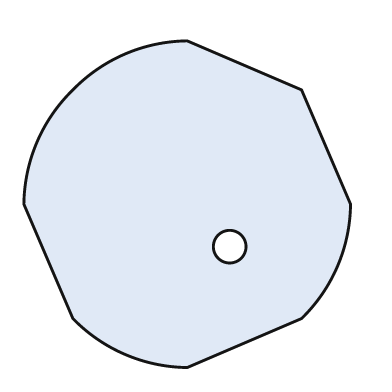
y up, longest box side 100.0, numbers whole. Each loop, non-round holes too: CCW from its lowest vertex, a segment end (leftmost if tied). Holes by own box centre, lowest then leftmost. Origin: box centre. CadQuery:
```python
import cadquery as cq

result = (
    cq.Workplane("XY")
    .moveTo(0.0, -50.0)
    .lineTo(35.0, -35.0)
    .threePointArc((46.0, -19.0), (50.0, 0.0))
    .lineTo(35.0, 35.0)
    .lineTo(0.0, 50.0)
    .threePointArc((-19.0, 46.0), (-35.0, 35.0))
    .threePointArc((-46.0, 19.0), (-50.0, 0.0))
    .lineTo(-35.0, -35.0)
    .threePointArc((-19.0, -46.0), (0.0, -50.0))
    .close()
    .moveTo(13.0, -13.0)
    .circle(5.0)
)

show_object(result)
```